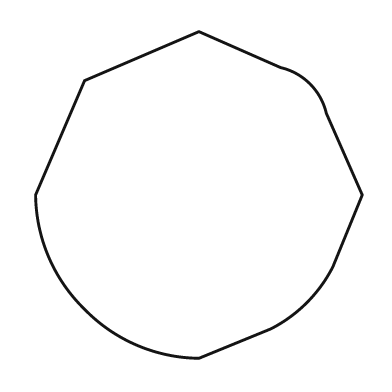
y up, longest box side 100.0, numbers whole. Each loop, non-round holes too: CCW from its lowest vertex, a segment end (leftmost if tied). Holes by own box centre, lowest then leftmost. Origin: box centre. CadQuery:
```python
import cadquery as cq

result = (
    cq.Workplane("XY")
    .moveTo(0.0, -50.0)
    .lineTo(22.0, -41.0)
    .threePointArc((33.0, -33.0), (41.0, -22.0))
    .lineTo(50.0, 0.0)
    .lineTo(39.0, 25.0)
    .threePointArc((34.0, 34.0), (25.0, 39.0))
    .lineTo(0.0, 50.0)
    .lineTo(-35.0, 35.0)
    .lineTo(-50.0, 0.0)
    .threePointArc((-46.0, -19.0), (-35.0, -35.0))
    .threePointArc((-19.0, -46.0), (0.0, -50.0))
    .close()
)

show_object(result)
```